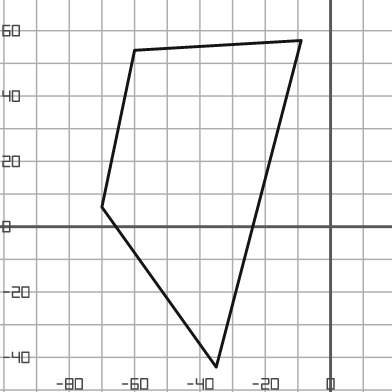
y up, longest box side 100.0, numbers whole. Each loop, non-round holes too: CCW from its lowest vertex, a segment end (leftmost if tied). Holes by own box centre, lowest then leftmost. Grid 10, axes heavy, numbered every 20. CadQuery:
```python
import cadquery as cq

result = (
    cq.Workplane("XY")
    .moveTo(-35.0, -43.0)
    .lineTo(-9.0, 57.0)
    .lineTo(-60.0, 54.0)
    .lineTo(-70.0, 6.0)
    .close()
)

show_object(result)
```